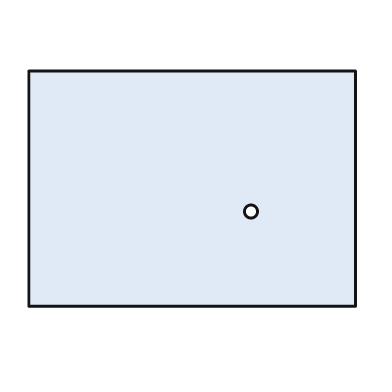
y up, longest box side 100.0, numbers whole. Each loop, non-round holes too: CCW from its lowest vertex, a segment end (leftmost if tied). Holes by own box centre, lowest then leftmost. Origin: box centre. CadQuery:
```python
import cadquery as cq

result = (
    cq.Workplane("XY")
    .moveTo(-50.0, -36.0)
    .lineTo(50.0, -36.0)
    .lineTo(50.0, 36.0)
    .lineTo(-50.0, 36.0)
    .close()
    .moveTo(18.0, -7.0)
    .circle(2.0)
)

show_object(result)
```